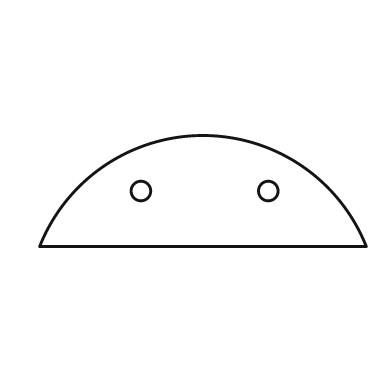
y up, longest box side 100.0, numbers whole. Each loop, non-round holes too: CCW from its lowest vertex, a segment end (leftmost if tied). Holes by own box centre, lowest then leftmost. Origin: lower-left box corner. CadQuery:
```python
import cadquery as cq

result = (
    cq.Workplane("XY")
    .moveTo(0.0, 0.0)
    .lineTo(100.0, 0.0)
    .threePointArc((50.0, 34.0), (0.0, 0.0))
    .close()
    .moveTo(31.0, 17.0)
    .circle(3.0)
    .moveTo(70.0, 17.0)
    .circle(3.0)
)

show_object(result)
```